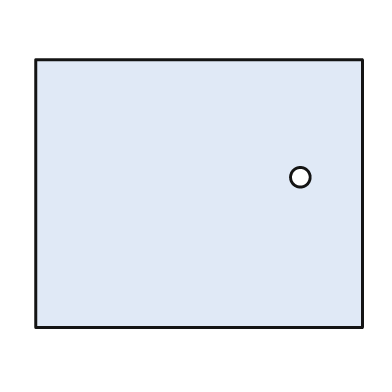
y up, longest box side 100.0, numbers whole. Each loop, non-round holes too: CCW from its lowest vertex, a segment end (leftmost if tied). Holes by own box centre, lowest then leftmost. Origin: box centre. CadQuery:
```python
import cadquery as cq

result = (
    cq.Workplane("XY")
    .moveTo(-50.0, -41.0)
    .lineTo(50.0, -41.0)
    .lineTo(50.0, 41.0)
    .lineTo(-50.0, 41.0)
    .close()
    .moveTo(31.0, 5.0)
    .circle(3.0)
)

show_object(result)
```